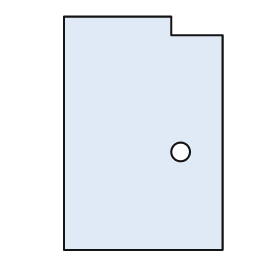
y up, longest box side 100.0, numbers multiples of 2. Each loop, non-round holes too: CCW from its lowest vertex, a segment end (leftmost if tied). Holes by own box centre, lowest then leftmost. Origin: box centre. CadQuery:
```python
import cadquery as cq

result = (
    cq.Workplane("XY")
    .moveTo(-34.0, -50.0)
    .lineTo(34.0, -50.0)
    .lineTo(34.0, 42.0)
    .lineTo(12.0, 42.0)
    .lineTo(12.0, 50.0)
    .lineTo(-34.0, 50.0)
    .close()
    .moveTo(16.0, -8.0)
    .circle(4.0)
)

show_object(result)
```